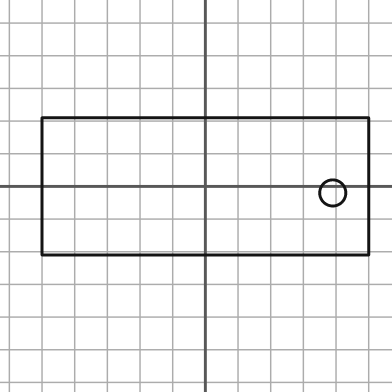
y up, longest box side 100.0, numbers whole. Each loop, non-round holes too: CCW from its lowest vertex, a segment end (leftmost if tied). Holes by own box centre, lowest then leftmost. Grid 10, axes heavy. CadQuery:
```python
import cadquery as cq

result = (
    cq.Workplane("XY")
    .moveTo(-50.0, -21.0)
    .lineTo(50.0, -21.0)
    .lineTo(50.0, 21.0)
    .lineTo(-50.0, 21.0)
    .close()
    .moveTo(39.0, -2.0)
    .circle(4.0)
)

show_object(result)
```